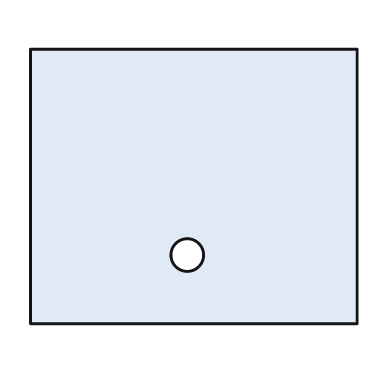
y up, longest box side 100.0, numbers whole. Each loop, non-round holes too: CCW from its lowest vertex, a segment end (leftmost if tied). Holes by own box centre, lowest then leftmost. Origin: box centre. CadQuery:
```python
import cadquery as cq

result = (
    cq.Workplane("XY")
    .moveTo(-50.0, -42.0)
    .lineTo(50.0, -42.0)
    .lineTo(50.0, 42.0)
    .lineTo(-50.0, 42.0)
    .close()
    .moveTo(-2.0, -21.0)
    .circle(5.0)
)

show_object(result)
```